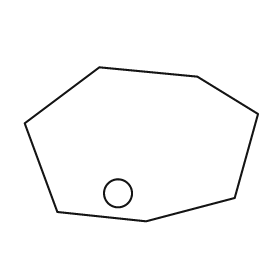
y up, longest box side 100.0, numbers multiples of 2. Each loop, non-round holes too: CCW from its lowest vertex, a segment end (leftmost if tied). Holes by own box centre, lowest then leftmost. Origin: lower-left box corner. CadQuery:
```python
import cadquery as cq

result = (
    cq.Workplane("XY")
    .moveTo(52.0, 0.0)
    .lineTo(90.0, 10.0)
    .lineTo(100.0, 46.0)
    .lineTo(74.0, 62.0)
    .lineTo(32.0, 66.0)
    .lineTo(0.0, 42.0)
    .lineTo(14.0, 4.0)
    .close()
    .moveTo(40.0, 12.0)
    .circle(6.0)
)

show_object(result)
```